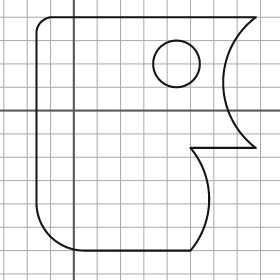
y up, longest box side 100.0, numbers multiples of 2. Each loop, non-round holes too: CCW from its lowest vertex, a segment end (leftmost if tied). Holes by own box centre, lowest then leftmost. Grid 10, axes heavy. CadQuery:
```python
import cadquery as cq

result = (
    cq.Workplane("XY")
    .moveTo(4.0, -60.0)
    .lineTo(50.0, -60.0)
    .threePointArc((58.0, -38.0), (50.0, -16.0))
    .lineTo(78.0, -16.0)
    .threePointArc((64.0, 12.0), (78.0, 40.0))
    .lineTo(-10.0, 40.0)
    .threePointArc((-14.0, 38.0), (-16.0, 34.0))
    .lineTo(-16.0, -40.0)
    .threePointArc((-10.0, -54.0), (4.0, -60.0))
    .close()
    .moveTo(44.0, 20.0)
    .circle(10.0)
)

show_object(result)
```